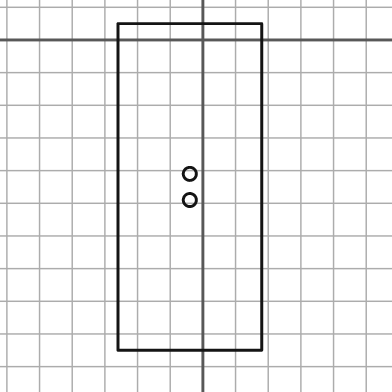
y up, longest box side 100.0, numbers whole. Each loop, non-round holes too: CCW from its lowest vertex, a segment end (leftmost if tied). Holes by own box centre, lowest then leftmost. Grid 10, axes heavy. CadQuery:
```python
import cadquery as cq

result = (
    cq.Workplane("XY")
    .moveTo(-26.0, -95.0)
    .lineTo(18.0, -95.0)
    .lineTo(18.0, 5.0)
    .lineTo(-26.0, 5.0)
    .close()
    .moveTo(-4.0, -49.0)
    .circle(2.0)
    .moveTo(-4.0, -41.0)
    .circle(2.0)
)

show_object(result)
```